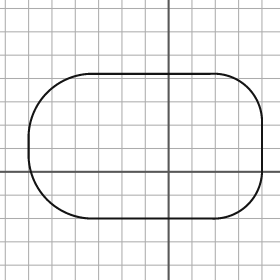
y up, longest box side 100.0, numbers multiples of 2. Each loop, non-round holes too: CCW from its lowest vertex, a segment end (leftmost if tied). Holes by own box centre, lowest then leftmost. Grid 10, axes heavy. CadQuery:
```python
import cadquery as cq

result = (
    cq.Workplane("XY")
    .moveTo(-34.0, -20.0)
    .lineTo(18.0, -20.0)
    .threePointArc((34.0, -14.0), (40.0, 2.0))
    .lineTo(40.0, 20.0)
    .threePointArc((34.0, 36.0), (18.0, 42.0))
    .lineTo(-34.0, 42.0)
    .threePointArc((-52.0, 34.0), (-60.0, 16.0))
    .lineTo(-60.0, 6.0)
    .threePointArc((-52.0, -12.0), (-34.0, -20.0))
    .close()
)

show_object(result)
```